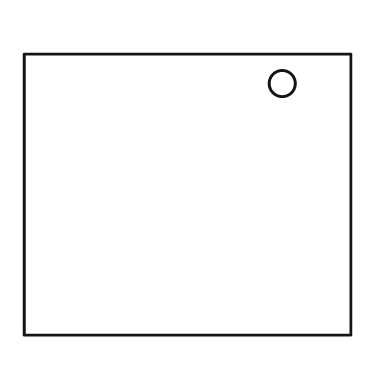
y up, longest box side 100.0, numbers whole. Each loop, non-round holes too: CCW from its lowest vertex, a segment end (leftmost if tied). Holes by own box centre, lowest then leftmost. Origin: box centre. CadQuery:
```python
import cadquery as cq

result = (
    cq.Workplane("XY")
    .moveTo(-50.0, -43.0)
    .lineTo(50.0, -43.0)
    .lineTo(50.0, 43.0)
    .lineTo(-50.0, 43.0)
    .close()
    .moveTo(29.0, 34.0)
    .circle(4.0)
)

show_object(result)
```